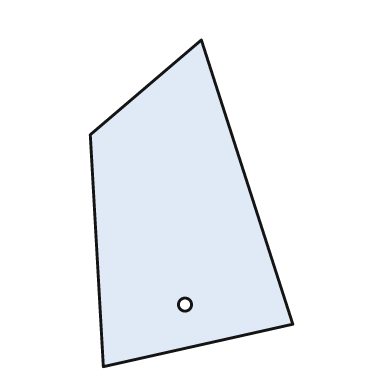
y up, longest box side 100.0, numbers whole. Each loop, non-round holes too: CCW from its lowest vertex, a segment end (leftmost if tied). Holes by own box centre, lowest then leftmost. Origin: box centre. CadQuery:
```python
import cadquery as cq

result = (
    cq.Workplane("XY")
    .moveTo(-27.0, -50.0)
    .lineTo(31.0, -37.0)
    .lineTo(3.0, 50.0)
    .lineTo(-31.0, 21.0)
    .close()
    .moveTo(-2.0, -31.0)
    .circle(2.0)
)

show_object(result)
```